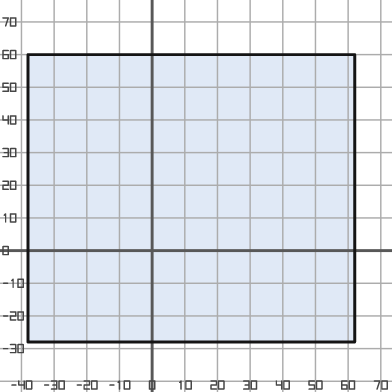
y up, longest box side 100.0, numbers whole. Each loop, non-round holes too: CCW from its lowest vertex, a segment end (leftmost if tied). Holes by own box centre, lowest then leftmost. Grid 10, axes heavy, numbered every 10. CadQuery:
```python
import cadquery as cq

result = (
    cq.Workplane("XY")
    .moveTo(-38.0, -28.0)
    .lineTo(62.0, -28.0)
    .lineTo(62.0, 60.0)
    .lineTo(-38.0, 60.0)
    .close()
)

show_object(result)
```